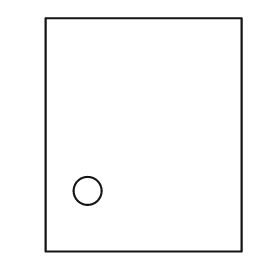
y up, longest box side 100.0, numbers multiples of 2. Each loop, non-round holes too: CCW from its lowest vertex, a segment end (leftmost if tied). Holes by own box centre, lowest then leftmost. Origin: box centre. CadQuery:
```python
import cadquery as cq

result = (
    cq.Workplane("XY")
    .moveTo(-42.0, -50.0)
    .lineTo(42.0, -50.0)
    .lineTo(42.0, 50.0)
    .lineTo(-42.0, 50.0)
    .close()
    .moveTo(-24.0, -24.0)
    .circle(6.0)
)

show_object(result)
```